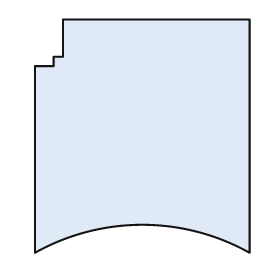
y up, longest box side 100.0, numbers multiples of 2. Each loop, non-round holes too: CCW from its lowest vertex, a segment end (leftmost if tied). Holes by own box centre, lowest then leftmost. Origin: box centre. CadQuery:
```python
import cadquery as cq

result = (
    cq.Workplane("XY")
    .moveTo(-46.0, -50.0)
    .threePointArc((0.0, -38.0), (46.0, -50.0))
    .lineTo(46.0, 50.0)
    .lineTo(-34.0, 50.0)
    .lineTo(-34.0, 34.0)
    .lineTo(-38.0, 34.0)
    .lineTo(-38.0, 30.0)
    .lineTo(-46.0, 30.0)
    .close()
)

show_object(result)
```